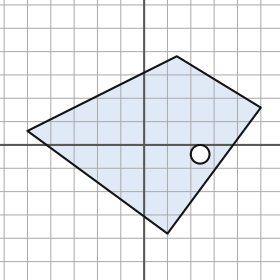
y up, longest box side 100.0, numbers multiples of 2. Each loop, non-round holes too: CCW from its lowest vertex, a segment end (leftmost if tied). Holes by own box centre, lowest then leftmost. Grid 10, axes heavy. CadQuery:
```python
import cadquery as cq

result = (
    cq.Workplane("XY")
    .moveTo(10.0, -38.0)
    .lineTo(50.0, 16.0)
    .lineTo(14.0, 38.0)
    .lineTo(-50.0, 6.0)
    .close()
    .moveTo(24.0, -4.0)
    .circle(4.0)
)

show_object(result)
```